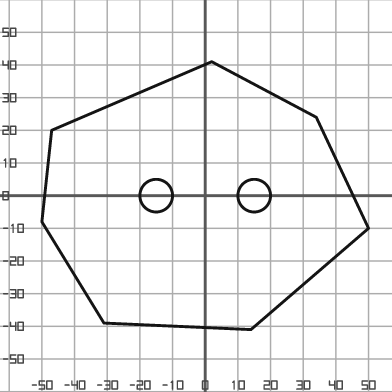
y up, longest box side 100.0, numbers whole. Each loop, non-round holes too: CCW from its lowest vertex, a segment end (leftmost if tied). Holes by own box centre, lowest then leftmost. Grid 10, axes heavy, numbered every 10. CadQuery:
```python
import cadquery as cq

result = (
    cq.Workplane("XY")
    .moveTo(14.0, -41.0)
    .lineTo(50.0, -10.0)
    .lineTo(34.0, 24.0)
    .lineTo(2.0, 41.0)
    .lineTo(-47.0, 20.0)
    .lineTo(-50.0, -8.0)
    .lineTo(-31.0, -39.0)
    .close()
    .moveTo(-15.0, 0.0)
    .circle(5.0)
    .moveTo(15.0, 0.0)
    .circle(5.0)
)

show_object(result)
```